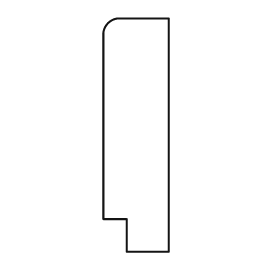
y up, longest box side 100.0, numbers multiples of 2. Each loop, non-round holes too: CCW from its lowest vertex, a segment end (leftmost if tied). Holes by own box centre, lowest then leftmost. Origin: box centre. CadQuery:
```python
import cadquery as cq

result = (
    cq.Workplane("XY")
    .moveTo(-4.0, -50.0)
    .lineTo(14.0, -50.0)
    .lineTo(14.0, 50.0)
    .lineTo(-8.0, 50.0)
    .threePointArc((-12.0, 48.0), (-14.0, 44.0))
    .lineTo(-14.0, -36.0)
    .lineTo(-4.0, -36.0)
    .close()
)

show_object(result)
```